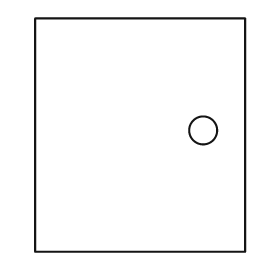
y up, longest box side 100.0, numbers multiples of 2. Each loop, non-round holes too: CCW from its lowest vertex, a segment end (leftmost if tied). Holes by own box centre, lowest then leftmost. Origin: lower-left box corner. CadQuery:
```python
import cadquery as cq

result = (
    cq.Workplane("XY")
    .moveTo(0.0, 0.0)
    .lineTo(90.0, 0.0)
    .lineTo(90.0, 100.0)
    .lineTo(0.0, 100.0)
    .close()
    .moveTo(72.0, 52.0)
    .circle(6.0)
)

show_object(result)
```